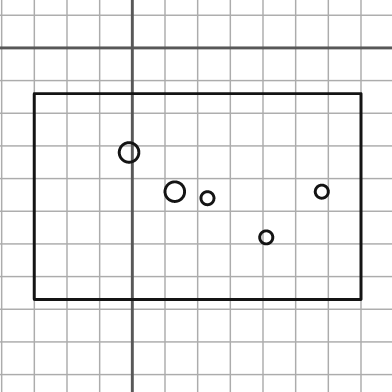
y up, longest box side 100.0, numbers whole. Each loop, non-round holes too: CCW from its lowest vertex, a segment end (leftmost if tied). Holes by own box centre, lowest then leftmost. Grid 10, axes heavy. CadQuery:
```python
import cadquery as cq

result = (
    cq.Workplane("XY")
    .moveTo(-30.0, -77.0)
    .lineTo(70.0, -77.0)
    .lineTo(70.0, -14.0)
    .lineTo(-30.0, -14.0)
    .close()
    .moveTo(41.0, -58.0)
    .circle(2.0)
    .moveTo(23.0, -46.0)
    .circle(2.0)
    .moveTo(13.0, -44.0)
    .circle(3.0)
    .moveTo(58.0, -44.0)
    .circle(2.0)
    .moveTo(-1.0, -32.0)
    .circle(3.0)
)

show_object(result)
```